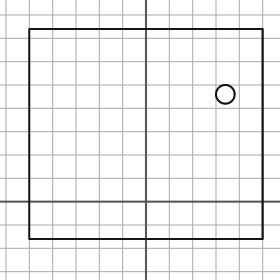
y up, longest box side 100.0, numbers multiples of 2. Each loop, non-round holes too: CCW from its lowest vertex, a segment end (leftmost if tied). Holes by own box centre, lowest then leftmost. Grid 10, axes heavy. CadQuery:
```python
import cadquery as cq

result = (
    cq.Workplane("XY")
    .moveTo(-50.0, -16.0)
    .lineTo(50.0, -16.0)
    .lineTo(50.0, 74.0)
    .lineTo(-50.0, 74.0)
    .close()
    .moveTo(34.0, 46.0)
    .circle(4.0)
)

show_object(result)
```